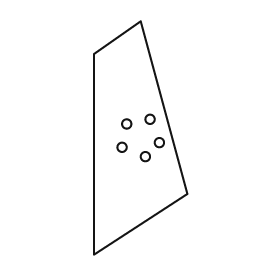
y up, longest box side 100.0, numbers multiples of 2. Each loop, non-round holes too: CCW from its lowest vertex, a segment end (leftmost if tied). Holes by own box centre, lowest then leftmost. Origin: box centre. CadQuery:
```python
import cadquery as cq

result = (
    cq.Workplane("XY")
    .moveTo(-20.0, -50.0)
    .lineTo(20.0, -24.0)
    .lineTo(0.0, 50.0)
    .lineTo(-20.0, 36.0)
    .close()
    .moveTo(2.0, -8.0)
    .circle(2.0)
    .moveTo(-8.0, -4.0)
    .circle(2.0)
    .moveTo(8.0, -2.0)
    .circle(2.0)
    .moveTo(-6.0, 6.0)
    .circle(2.0)
    .moveTo(4.0, 8.0)
    .circle(2.0)
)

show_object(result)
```